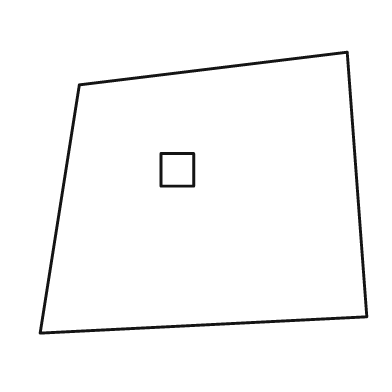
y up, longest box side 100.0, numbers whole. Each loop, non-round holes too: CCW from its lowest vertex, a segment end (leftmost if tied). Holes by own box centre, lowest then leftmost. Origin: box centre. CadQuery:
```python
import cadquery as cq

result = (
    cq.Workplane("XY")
    .moveTo(-50.0, -43.0)
    .lineTo(50.0, -38.0)
    .lineTo(44.0, 43.0)
    .lineTo(-38.0, 33.0)
    .close()
    .moveTo(-13.0, 2.0)
    .lineTo(-3.0, 2.0)
    .lineTo(-3.0, 12.0)
    .lineTo(-13.0, 12.0)
    .close()
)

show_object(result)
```